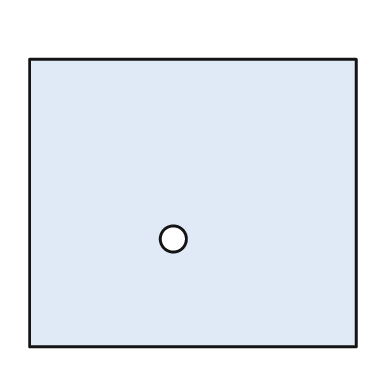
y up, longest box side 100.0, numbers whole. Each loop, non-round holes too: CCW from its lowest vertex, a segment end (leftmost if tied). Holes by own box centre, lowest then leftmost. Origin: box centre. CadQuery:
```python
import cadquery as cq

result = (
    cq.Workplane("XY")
    .moveTo(-50.0, -44.0)
    .lineTo(50.0, -44.0)
    .lineTo(50.0, 44.0)
    .lineTo(-50.0, 44.0)
    .close()
    .moveTo(-6.0, -11.0)
    .circle(4.0)
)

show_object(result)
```